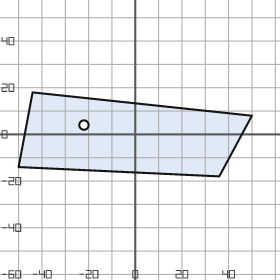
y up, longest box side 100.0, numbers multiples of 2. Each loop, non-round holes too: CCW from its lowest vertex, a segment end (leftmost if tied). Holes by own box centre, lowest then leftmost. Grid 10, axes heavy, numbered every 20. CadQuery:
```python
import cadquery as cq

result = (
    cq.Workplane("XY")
    .moveTo(36.0, -18.0)
    .lineTo(50.0, 8.0)
    .lineTo(-44.0, 18.0)
    .lineTo(-50.0, -14.0)
    .close()
    .moveTo(-22.0, 4.0)
    .circle(2.0)
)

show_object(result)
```